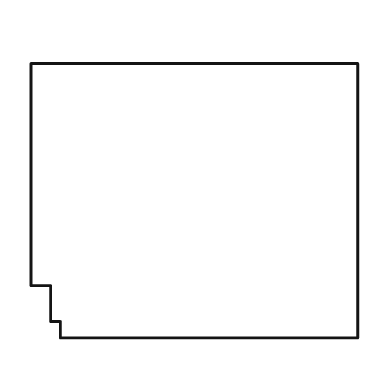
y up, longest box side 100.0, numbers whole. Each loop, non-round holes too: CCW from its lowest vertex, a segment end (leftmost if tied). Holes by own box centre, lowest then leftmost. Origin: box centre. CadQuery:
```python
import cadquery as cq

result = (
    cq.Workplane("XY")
    .moveTo(-41.0, -42.0)
    .lineTo(50.0, -42.0)
    .lineTo(50.0, 42.0)
    .lineTo(-50.0, 42.0)
    .lineTo(-50.0, -26.0)
    .lineTo(-44.0, -26.0)
    .lineTo(-44.0, -37.0)
    .lineTo(-41.0, -37.0)
    .close()
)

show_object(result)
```